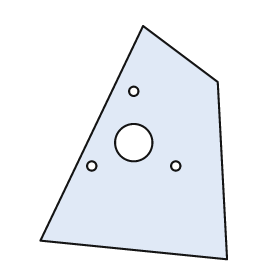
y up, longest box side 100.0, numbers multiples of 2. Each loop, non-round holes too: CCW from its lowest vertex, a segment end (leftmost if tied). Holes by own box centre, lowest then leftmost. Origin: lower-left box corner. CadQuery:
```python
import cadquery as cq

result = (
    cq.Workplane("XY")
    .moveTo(80.0, 0.0)
    .lineTo(76.0, 76.0)
    .lineTo(44.0, 100.0)
    .lineTo(0.0, 8.0)
    .close()
    .moveTo(22.0, 40.0)
    .circle(2.0)
    .moveTo(58.0, 40.0)
    .circle(2.0)
    .moveTo(40.0, 50.0)
    .circle(8.0)
    .moveTo(40.0, 72.0)
    .circle(2.0)
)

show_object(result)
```